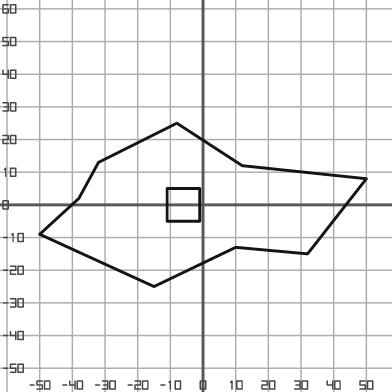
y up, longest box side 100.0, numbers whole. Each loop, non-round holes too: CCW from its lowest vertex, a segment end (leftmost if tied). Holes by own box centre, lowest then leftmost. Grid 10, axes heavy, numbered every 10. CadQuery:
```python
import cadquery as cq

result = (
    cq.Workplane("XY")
    .moveTo(-15.0, -25.0)
    .lineTo(10.0, -13.0)
    .lineTo(32.0, -15.0)
    .lineTo(50.0, 8.0)
    .lineTo(12.0, 12.0)
    .lineTo(-8.0, 25.0)
    .lineTo(-32.0, 13.0)
    .lineTo(-38.0, 2.0)
    .lineTo(-50.0, -9.0)
    .close()
    .moveTo(-11.0, -5.0)
    .lineTo(-1.0, -5.0)
    .lineTo(-1.0, 5.0)
    .lineTo(-11.0, 5.0)
    .close()
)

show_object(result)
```